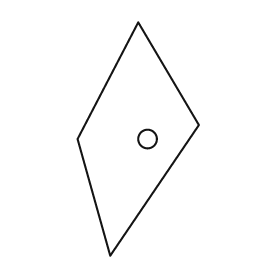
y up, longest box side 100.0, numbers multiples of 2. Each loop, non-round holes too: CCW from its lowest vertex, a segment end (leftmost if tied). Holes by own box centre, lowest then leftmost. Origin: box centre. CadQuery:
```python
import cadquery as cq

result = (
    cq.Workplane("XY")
    .moveTo(-12.0, -50.0)
    .lineTo(26.0, 6.0)
    .lineTo(0.0, 50.0)
    .lineTo(-26.0, 0.0)
    .close()
    .moveTo(4.0, 0.0)
    .circle(4.0)
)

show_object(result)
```